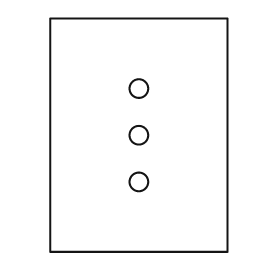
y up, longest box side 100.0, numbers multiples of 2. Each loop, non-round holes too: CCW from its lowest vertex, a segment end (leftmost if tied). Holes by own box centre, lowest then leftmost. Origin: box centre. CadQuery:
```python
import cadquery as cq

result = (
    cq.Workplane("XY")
    .moveTo(-38.0, -50.0)
    .lineTo(38.0, -50.0)
    .lineTo(38.0, 50.0)
    .lineTo(-38.0, 50.0)
    .close()
    .moveTo(0.0, -20.0)
    .circle(4.0)
    .moveTo(0.0, 0.0)
    .circle(4.0)
    .moveTo(0.0, 20.0)
    .circle(4.0)
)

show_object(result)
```